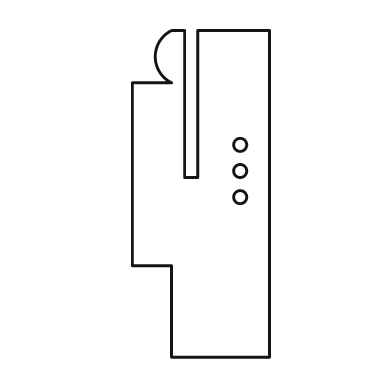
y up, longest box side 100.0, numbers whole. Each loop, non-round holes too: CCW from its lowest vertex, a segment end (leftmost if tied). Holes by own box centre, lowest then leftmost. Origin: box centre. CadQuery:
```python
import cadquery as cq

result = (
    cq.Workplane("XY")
    .moveTo(-9.0, -50.0)
    .lineTo(21.0, -50.0)
    .lineTo(21.0, 50.0)
    .lineTo(-1.0, 50.0)
    .lineTo(-1.0, 5.0)
    .lineTo(-5.0, 5.0)
    .lineTo(-5.0, 50.0)
    .lineTo(-9.0, 50.0)
    .threePointArc((-14.0, 42.0), (-9.0, 34.0))
    .lineTo(-21.0, 34.0)
    .lineTo(-21.0, -22.0)
    .lineTo(-9.0, -22.0)
    .close()
    .moveTo(12.0, -1.0)
    .circle(2.0)
    .moveTo(12.0, 7.0)
    .circle(2.0)
    .moveTo(12.0, 15.0)
    .circle(2.0)
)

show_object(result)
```